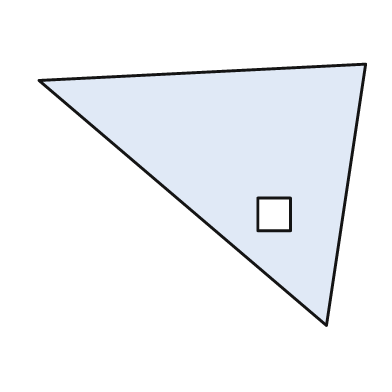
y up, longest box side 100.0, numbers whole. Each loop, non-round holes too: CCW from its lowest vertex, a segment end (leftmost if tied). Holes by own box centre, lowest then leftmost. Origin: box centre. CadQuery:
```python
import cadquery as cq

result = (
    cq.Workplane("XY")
    .moveTo(38.0, -40.0)
    .lineTo(50.0, 40.0)
    .lineTo(-50.0, 35.0)
    .close()
    .moveTo(17.0, -11.0)
    .lineTo(27.0, -11.0)
    .lineTo(27.0, -1.0)
    .lineTo(17.0, -1.0)
    .close()
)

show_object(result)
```